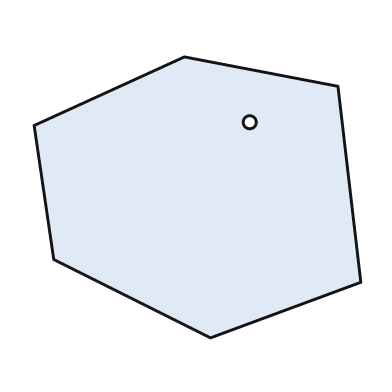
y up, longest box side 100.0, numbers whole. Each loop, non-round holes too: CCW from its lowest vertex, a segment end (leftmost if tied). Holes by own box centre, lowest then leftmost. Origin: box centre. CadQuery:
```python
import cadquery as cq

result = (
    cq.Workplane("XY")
    .moveTo(4.0, -43.0)
    .lineTo(50.0, -26.0)
    .lineTo(43.0, 34.0)
    .lineTo(-4.0, 43.0)
    .lineTo(-50.0, 22.0)
    .lineTo(-44.0, -19.0)
    .close()
    .moveTo(16.0, 23.0)
    .circle(2.0)
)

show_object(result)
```